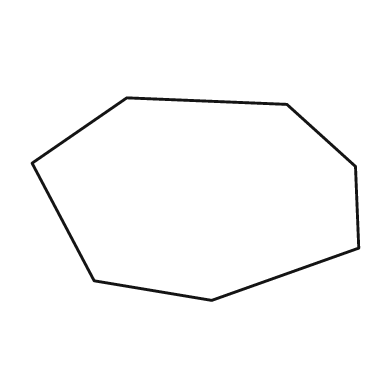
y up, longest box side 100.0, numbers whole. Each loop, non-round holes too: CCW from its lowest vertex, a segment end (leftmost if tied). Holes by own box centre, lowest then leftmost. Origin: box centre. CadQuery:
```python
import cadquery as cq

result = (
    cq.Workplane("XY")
    .moveTo(5.0, -31.0)
    .lineTo(50.0, -15.0)
    .lineTo(49.0, 10.0)
    .lineTo(28.0, 29.0)
    .lineTo(-21.0, 31.0)
    .lineTo(-50.0, 11.0)
    .lineTo(-31.0, -25.0)
    .close()
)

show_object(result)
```